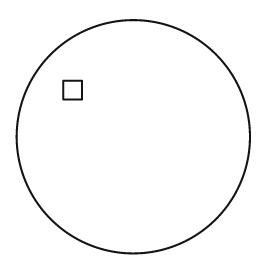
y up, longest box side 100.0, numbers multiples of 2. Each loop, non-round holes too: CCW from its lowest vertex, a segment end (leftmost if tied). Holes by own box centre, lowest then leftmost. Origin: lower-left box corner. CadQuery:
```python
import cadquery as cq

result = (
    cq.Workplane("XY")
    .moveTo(50.0, 50.0)
    .circle(50.0)
    .moveTo(20.0, 66.0)
    .lineTo(28.0, 66.0)
    .lineTo(28.0, 74.0)
    .lineTo(20.0, 74.0)
    .close()
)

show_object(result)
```